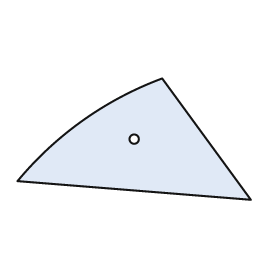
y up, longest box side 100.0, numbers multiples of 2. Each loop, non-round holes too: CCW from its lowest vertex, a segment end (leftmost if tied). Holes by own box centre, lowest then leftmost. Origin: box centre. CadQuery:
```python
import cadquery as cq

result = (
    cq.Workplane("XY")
    .moveTo(50.0, -26.0)
    .lineTo(12.0, 26.0)
    .threePointArc((-22.0, 8.0), (-50.0, -18.0))
    .close()
    .moveTo(0.0, 0.0)
    .circle(2.0)
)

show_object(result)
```